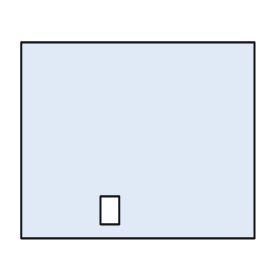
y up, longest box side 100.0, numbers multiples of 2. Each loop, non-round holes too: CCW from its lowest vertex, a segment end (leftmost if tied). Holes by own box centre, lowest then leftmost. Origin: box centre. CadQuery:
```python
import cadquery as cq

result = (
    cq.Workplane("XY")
    .moveTo(-50.0, -42.0)
    .lineTo(50.0, -42.0)
    .lineTo(50.0, 42.0)
    .lineTo(-50.0, 42.0)
    .close()
    .moveTo(-16.0, -36.0)
    .lineTo(-8.0, -36.0)
    .lineTo(-8.0, -24.0)
    .lineTo(-16.0, -24.0)
    .close()
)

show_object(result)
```